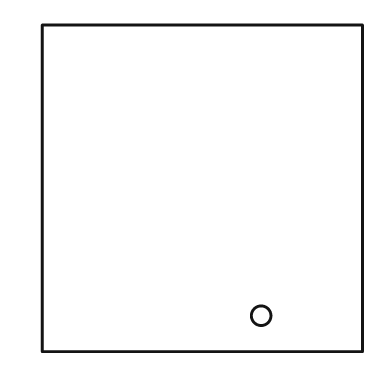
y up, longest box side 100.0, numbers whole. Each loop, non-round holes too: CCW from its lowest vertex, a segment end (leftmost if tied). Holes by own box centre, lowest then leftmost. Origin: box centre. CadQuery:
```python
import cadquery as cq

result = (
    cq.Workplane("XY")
    .moveTo(-49.0, -50.0)
    .lineTo(49.0, -50.0)
    .lineTo(49.0, 50.0)
    .lineTo(-49.0, 50.0)
    .close()
    .moveTo(18.0, -39.0)
    .circle(3.0)
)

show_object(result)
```